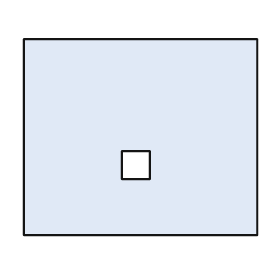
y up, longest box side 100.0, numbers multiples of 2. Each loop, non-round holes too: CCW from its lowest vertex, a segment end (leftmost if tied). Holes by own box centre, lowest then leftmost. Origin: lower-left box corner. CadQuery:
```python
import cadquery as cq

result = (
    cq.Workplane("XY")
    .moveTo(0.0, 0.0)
    .lineTo(100.0, 0.0)
    .lineTo(100.0, 84.0)
    .lineTo(0.0, 84.0)
    .close()
    .moveTo(42.0, 24.0)
    .lineTo(54.0, 24.0)
    .lineTo(54.0, 36.0)
    .lineTo(42.0, 36.0)
    .close()
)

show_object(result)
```